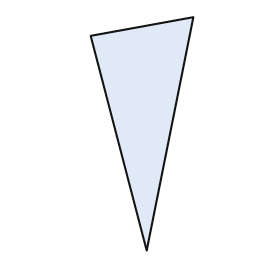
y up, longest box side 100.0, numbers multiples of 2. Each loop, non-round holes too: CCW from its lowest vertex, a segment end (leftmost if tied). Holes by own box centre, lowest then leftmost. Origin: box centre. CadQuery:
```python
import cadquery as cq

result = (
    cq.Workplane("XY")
    .moveTo(2.0, -50.0)
    .lineTo(22.0, 50.0)
    .lineTo(-22.0, 42.0)
    .close()
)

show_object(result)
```